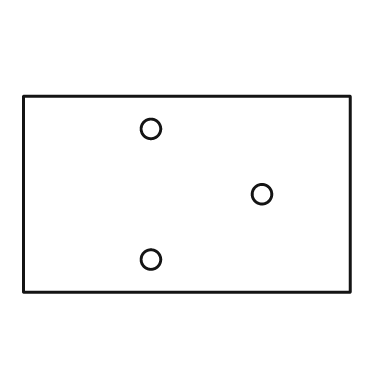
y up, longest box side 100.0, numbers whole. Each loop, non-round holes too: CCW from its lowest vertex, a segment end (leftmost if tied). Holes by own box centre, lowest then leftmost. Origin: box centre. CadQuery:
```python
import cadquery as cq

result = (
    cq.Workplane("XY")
    .moveTo(-50.0, -30.0)
    .lineTo(50.0, -30.0)
    .lineTo(50.0, 30.0)
    .lineTo(-50.0, 30.0)
    .close()
    .moveTo(-11.0, -20.0)
    .circle(3.0)
    .moveTo(23.0, 0.0)
    .circle(3.0)
    .moveTo(-11.0, 20.0)
    .circle(3.0)
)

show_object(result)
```